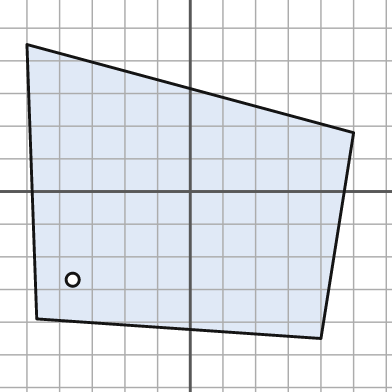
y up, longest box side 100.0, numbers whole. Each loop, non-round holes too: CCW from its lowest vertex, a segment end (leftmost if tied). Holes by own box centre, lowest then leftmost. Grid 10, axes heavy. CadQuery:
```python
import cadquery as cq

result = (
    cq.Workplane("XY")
    .moveTo(40.0, -45.0)
    .lineTo(50.0, 18.0)
    .lineTo(-50.0, 45.0)
    .lineTo(-47.0, -39.0)
    .close()
    .moveTo(-36.0, -27.0)
    .circle(2.0)
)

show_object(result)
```